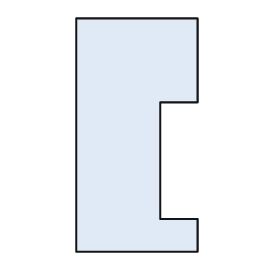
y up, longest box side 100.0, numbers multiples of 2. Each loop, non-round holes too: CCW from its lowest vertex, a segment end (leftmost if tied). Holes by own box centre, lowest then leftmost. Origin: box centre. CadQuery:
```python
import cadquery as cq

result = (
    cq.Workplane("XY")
    .moveTo(-26.0, -50.0)
    .lineTo(26.0, -50.0)
    .lineTo(26.0, -36.0)
    .lineTo(10.0, -36.0)
    .lineTo(10.0, 14.0)
    .lineTo(26.0, 14.0)
    .lineTo(26.0, 50.0)
    .lineTo(-26.0, 50.0)
    .close()
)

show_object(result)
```